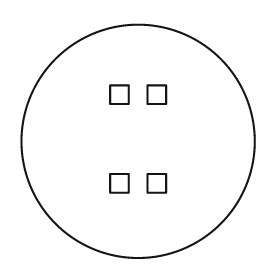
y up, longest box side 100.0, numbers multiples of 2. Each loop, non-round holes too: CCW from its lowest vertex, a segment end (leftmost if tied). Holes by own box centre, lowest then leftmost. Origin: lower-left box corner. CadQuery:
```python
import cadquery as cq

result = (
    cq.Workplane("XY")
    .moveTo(50.0, 50.0)
    .circle(50.0)
    .moveTo(38.0, 28.0)
    .lineTo(46.0, 28.0)
    .lineTo(46.0, 36.0)
    .lineTo(38.0, 36.0)
    .close()
    .moveTo(54.0, 28.0)
    .lineTo(62.0, 28.0)
    .lineTo(62.0, 36.0)
    .lineTo(54.0, 36.0)
    .close()
    .moveTo(38.0, 66.0)
    .lineTo(46.0, 66.0)
    .lineTo(46.0, 74.0)
    .lineTo(38.0, 74.0)
    .close()
    .moveTo(54.0, 66.0)
    .lineTo(62.0, 66.0)
    .lineTo(62.0, 74.0)
    .lineTo(54.0, 74.0)
    .close()
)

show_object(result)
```